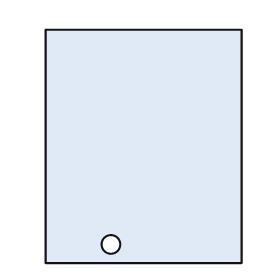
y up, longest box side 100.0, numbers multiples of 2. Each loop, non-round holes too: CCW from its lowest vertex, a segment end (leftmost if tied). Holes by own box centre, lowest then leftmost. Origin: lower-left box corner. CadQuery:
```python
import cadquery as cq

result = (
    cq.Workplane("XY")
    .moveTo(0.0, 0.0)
    .lineTo(84.0, 0.0)
    .lineTo(84.0, 100.0)
    .lineTo(0.0, 100.0)
    .close()
    .moveTo(28.0, 8.0)
    .circle(4.0)
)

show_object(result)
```